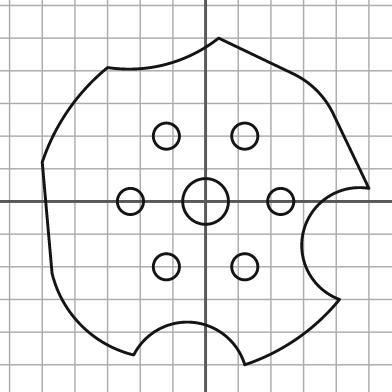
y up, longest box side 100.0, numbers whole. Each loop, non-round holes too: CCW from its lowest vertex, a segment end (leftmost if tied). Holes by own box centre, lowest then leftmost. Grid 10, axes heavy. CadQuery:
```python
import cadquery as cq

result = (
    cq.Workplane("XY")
    .moveTo(12.0, -50.0)
    .threePointArc((28.0, -42.0), (41.0, -30.0))
    .threePointArc((30.0, -9.0), (50.0, 4.0))
    .lineTo(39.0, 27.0)
    .threePointArc((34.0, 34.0), (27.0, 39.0))
    .lineTo(4.0, 50.0)
    .threePointArc((-12.0, 42.0), (-30.0, 41.0))
    .threePointArc((-42.0, 28.0), (-50.0, 12.0))
    .lineTo(-47.0, -22.0)
    .threePointArc((-38.0, -38.0), (-22.0, -47.0))
    .threePointArc((-4.0, -37.0), (12.0, -50.0))
    .close()
    .moveTo(-12.0, -20.0)
    .circle(4.0)
    .moveTo(12.0, -20.0)
    .circle(4.0)
    .moveTo(-23.0, 0.0)
    .circle(4.0)
    .moveTo(0.0, 0.0)
    .circle(7.0)
    .moveTo(23.0, 0.0)
    .circle(4.0)
    .moveTo(-12.0, 20.0)
    .circle(4.0)
    .moveTo(12.0, 20.0)
    .circle(4.0)
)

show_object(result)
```